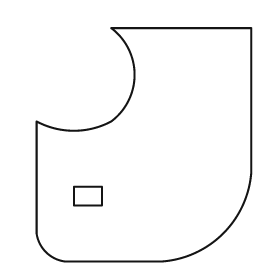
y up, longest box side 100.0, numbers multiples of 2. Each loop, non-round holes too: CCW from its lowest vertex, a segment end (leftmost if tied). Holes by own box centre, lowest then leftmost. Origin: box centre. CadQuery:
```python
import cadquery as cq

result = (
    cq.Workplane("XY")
    .moveTo(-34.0, -50.0)
    .lineTo(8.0, -50.0)
    .threePointArc((34.0, -38.0), (46.0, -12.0))
    .lineTo(46.0, 50.0)
    .lineTo(-14.0, 50.0)
    .threePointArc((-4.0, 30.0), (-14.0, 10.0))
    .threePointArc((-30.0, 6.0), (-46.0, 10.0))
    .lineTo(-46.0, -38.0)
    .threePointArc((-42.0, -46.0), (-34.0, -50.0))
    .close()
    .moveTo(-30.0, -26.0)
    .lineTo(-18.0, -26.0)
    .lineTo(-18.0, -18.0)
    .lineTo(-30.0, -18.0)
    .close()
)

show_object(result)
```